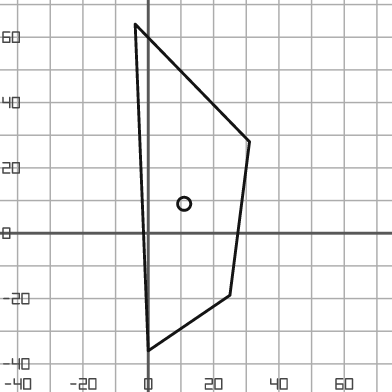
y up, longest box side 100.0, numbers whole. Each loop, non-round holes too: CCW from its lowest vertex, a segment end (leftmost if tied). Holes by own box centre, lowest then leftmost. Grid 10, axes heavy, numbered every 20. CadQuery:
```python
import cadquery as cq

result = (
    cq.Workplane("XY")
    .moveTo(0.0, -36.0)
    .lineTo(25.0, -19.0)
    .lineTo(31.0, 28.0)
    .lineTo(-4.0, 64.0)
    .close()
    .moveTo(11.0, 9.0)
    .circle(2.0)
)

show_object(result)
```